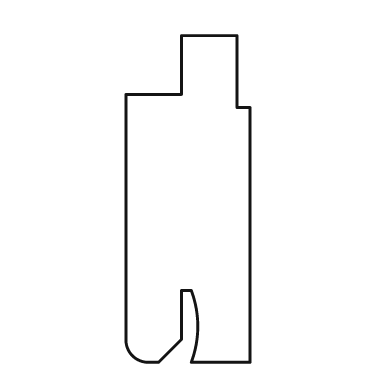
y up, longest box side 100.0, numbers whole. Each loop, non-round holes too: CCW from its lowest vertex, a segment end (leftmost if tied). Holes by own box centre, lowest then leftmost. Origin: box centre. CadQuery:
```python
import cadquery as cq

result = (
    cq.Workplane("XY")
    .moveTo(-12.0, -50.0)
    .lineTo(-9.0, -50.0)
    .lineTo(-2.0, -43.0)
    .lineTo(-2.0, -28.0)
    .lineTo(1.0, -28.0)
    .threePointArc((3.0, -39.0), (1.0, -50.0))
    .lineTo(19.0, -50.0)
    .lineTo(19.0, 28.0)
    .lineTo(15.0, 28.0)
    .lineTo(15.0, 50.0)
    .lineTo(-2.0, 50.0)
    .lineTo(-2.0, 32.0)
    .lineTo(-19.0, 32.0)
    .lineTo(-19.0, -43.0)
    .threePointArc((-17.0, -48.0), (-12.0, -50.0))
    .close()
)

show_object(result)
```